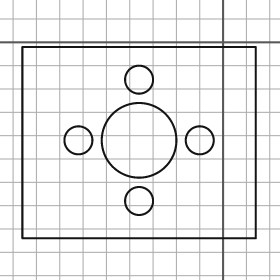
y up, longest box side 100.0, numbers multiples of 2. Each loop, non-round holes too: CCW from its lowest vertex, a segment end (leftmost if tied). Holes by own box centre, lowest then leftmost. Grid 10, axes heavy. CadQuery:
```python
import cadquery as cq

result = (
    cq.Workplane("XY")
    .moveTo(-86.0, -84.0)
    .lineTo(14.0, -84.0)
    .lineTo(14.0, -2.0)
    .lineTo(-86.0, -2.0)
    .close()
    .moveTo(-36.0, -68.0)
    .circle(6.0)
    .moveTo(-62.0, -42.0)
    .circle(6.0)
    .moveTo(-36.0, -42.0)
    .circle(16.0)
    .moveTo(-10.0, -42.0)
    .circle(6.0)
    .moveTo(-36.0, -16.0)
    .circle(6.0)
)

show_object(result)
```